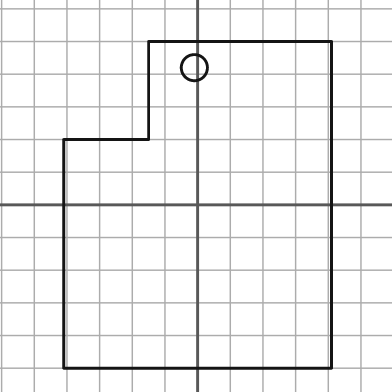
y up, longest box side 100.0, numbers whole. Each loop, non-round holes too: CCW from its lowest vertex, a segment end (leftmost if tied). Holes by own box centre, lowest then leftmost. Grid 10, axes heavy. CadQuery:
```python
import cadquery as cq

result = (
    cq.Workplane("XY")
    .moveTo(-41.0, -50.0)
    .lineTo(41.0, -50.0)
    .lineTo(41.0, 50.0)
    .lineTo(-15.0, 50.0)
    .lineTo(-15.0, 20.0)
    .lineTo(-41.0, 20.0)
    .close()
    .moveTo(-1.0, 42.0)
    .circle(4.0)
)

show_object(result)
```